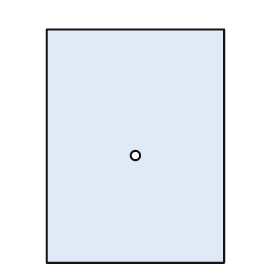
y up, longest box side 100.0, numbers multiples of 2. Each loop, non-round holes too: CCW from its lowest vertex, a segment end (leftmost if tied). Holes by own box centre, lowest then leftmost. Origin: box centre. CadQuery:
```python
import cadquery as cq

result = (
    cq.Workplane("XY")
    .moveTo(-38.0, -50.0)
    .lineTo(38.0, -50.0)
    .lineTo(38.0, 50.0)
    .lineTo(-38.0, 50.0)
    .close()
    .moveTo(0.0, -4.0)
    .circle(2.0)
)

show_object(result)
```